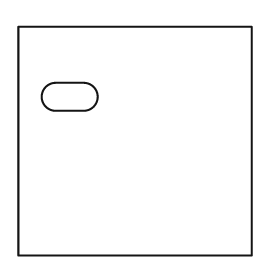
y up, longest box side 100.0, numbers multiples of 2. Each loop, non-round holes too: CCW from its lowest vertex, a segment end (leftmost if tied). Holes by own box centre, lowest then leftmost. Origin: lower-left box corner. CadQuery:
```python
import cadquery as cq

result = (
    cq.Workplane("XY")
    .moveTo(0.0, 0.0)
    .lineTo(100.0, 0.0)
    .lineTo(100.0, 98.0)
    .lineTo(0.0, 98.0)
    .close()
    .moveTo(16.0, 62.0)
    .lineTo(28.0, 62.0)
    .threePointArc((34.0, 68.0), (28.0, 74.0))
    .lineTo(16.0, 74.0)
    .threePointArc((10.0, 68.0), (16.0, 62.0))
    .close()
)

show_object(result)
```